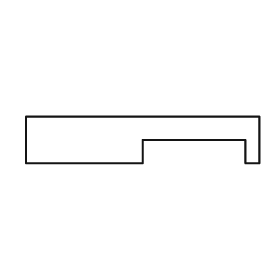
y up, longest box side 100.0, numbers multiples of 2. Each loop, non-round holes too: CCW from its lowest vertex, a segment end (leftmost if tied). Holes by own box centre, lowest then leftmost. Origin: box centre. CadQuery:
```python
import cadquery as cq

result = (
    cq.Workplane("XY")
    .moveTo(-50.0, -10.0)
    .lineTo(0.0, -10.0)
    .lineTo(0.0, 0.0)
    .lineTo(44.0, 0.0)
    .lineTo(44.0, -10.0)
    .lineTo(50.0, -10.0)
    .lineTo(50.0, 10.0)
    .lineTo(-50.0, 10.0)
    .close()
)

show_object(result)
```